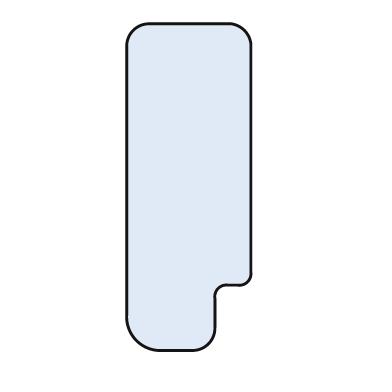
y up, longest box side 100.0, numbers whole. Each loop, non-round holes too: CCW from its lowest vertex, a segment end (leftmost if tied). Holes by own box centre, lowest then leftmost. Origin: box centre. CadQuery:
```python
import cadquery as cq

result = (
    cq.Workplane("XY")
    .moveTo(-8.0, -50.0)
    .lineTo(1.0, -50.0)
    .threePointArc((6.0, -48.0), (8.0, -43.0))
    .lineTo(8.0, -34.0)
    .threePointArc((9.0, -31.0), (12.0, -30.0))
    .lineTo(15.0, -30.0)
    .threePointArc((18.0, -29.0), (19.0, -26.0))
    .lineTo(19.0, 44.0)
    .threePointArc((17.0, 48.0), (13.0, 50.0))
    .lineTo(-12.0, 50.0)
    .threePointArc((-17.0, 48.0), (-19.0, 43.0))
    .lineTo(-19.0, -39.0)
    .threePointArc((-16.0, -47.0), (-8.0, -50.0))
    .close()
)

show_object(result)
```